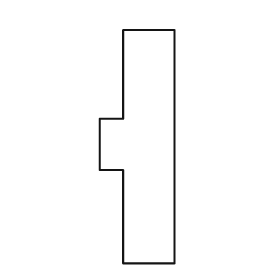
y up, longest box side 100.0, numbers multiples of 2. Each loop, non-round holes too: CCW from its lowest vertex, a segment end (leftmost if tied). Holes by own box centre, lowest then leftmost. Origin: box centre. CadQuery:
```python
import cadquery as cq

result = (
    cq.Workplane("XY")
    .moveTo(-6.0, -50.0)
    .lineTo(16.0, -50.0)
    .lineTo(16.0, 50.0)
    .lineTo(-6.0, 50.0)
    .lineTo(-6.0, 12.0)
    .lineTo(-16.0, 12.0)
    .lineTo(-16.0, -10.0)
    .lineTo(-6.0, -10.0)
    .close()
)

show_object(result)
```